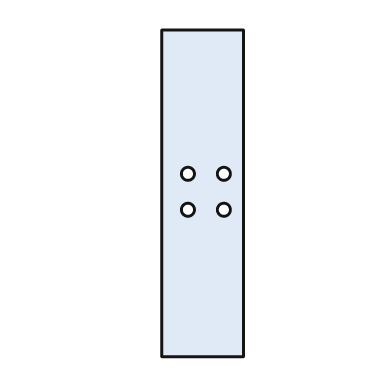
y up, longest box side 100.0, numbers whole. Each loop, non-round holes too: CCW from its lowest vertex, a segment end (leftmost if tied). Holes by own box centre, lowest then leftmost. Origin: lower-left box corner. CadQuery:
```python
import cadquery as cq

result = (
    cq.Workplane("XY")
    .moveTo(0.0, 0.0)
    .lineTo(25.0, 0.0)
    .lineTo(25.0, 100.0)
    .lineTo(0.0, 100.0)
    .close()
    .moveTo(8.0, 45.0)
    .circle(2.0)
    .moveTo(19.0, 45.0)
    .circle(2.0)
    .moveTo(8.0, 56.0)
    .circle(2.0)
    .moveTo(19.0, 56.0)
    .circle(2.0)
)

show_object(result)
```